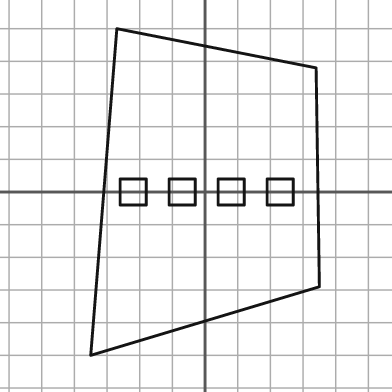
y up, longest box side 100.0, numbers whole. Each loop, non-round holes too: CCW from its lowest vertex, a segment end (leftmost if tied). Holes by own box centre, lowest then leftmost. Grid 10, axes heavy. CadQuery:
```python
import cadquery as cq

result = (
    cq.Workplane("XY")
    .moveTo(-35.0, -50.0)
    .lineTo(35.0, -29.0)
    .lineTo(34.0, 38.0)
    .lineTo(-27.0, 50.0)
    .close()
    .moveTo(-26.0, -4.0)
    .lineTo(-18.0, -4.0)
    .lineTo(-18.0, 4.0)
    .lineTo(-26.0, 4.0)
    .close()
    .moveTo(-11.0, -4.0)
    .lineTo(-3.0, -4.0)
    .lineTo(-3.0, 4.0)
    .lineTo(-11.0, 4.0)
    .close()
    .moveTo(4.0, -4.0)
    .lineTo(12.0, -4.0)
    .lineTo(12.0, 4.0)
    .lineTo(4.0, 4.0)
    .close()
    .moveTo(19.0, -4.0)
    .lineTo(27.0, -4.0)
    .lineTo(27.0, 4.0)
    .lineTo(19.0, 4.0)
    .close()
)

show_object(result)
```